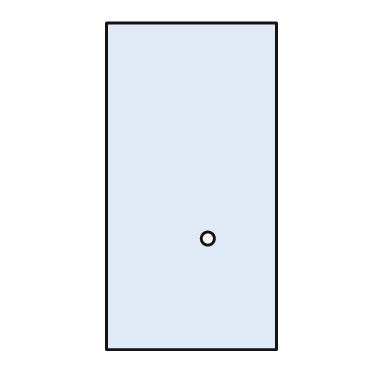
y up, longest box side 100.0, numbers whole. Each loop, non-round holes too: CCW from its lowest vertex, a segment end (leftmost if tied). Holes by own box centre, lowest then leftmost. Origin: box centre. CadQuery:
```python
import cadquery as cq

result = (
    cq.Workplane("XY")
    .moveTo(-26.0, -50.0)
    .lineTo(26.0, -50.0)
    .lineTo(26.0, 50.0)
    .lineTo(-26.0, 50.0)
    .close()
    .moveTo(5.0, -16.0)
    .circle(2.0)
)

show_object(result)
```